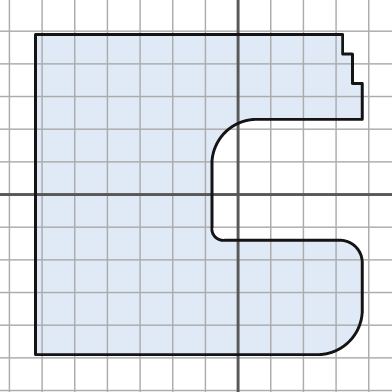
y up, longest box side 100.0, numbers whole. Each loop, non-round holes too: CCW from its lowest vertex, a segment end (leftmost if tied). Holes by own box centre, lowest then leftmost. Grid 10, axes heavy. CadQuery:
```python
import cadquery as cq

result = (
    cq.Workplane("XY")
    .moveTo(-62.0, -49.0)
    .lineTo(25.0, -49.0)
    .threePointArc((34.0, -45.0), (38.0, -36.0))
    .lineTo(38.0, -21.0)
    .threePointArc((36.0, -16.0), (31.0, -14.0))
    .lineTo(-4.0, -14.0)
    .threePointArc((-7.0, -13.0), (-8.0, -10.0))
    .lineTo(-8.0, 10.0)
    .threePointArc((-4.0, 19.0), (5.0, 23.0))
    .lineTo(38.0, 23.0)
    .lineTo(38.0, 34.0)
    .lineTo(35.0, 34.0)
    .lineTo(35.0, 43.0)
    .lineTo(32.0, 43.0)
    .lineTo(32.0, 49.0)
    .lineTo(-62.0, 49.0)
    .close()
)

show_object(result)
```